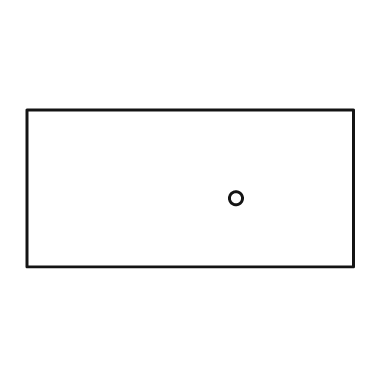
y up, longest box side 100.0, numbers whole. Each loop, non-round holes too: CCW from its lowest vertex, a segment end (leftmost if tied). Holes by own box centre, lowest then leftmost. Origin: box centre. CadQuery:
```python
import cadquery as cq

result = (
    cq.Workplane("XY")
    .moveTo(-50.0, -24.0)
    .lineTo(50.0, -24.0)
    .lineTo(50.0, 24.0)
    .lineTo(-50.0, 24.0)
    .close()
    .moveTo(14.0, -3.0)
    .circle(2.0)
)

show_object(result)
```